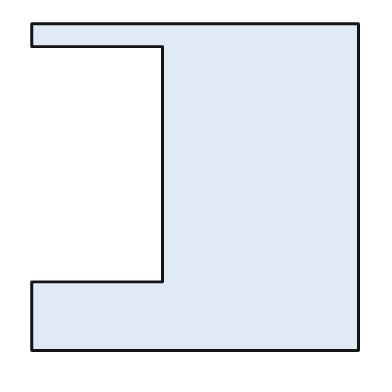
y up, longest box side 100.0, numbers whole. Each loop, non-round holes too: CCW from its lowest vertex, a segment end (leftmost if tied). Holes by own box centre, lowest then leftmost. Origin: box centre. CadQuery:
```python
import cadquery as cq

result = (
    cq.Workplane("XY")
    .moveTo(-50.0, -50.0)
    .lineTo(50.0, -50.0)
    .lineTo(50.0, 50.0)
    .lineTo(-50.0, 50.0)
    .lineTo(-50.0, 43.0)
    .lineTo(-10.0, 43.0)
    .lineTo(-10.0, -29.0)
    .lineTo(-50.0, -29.0)
    .close()
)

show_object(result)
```